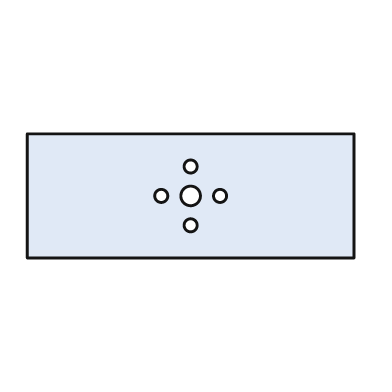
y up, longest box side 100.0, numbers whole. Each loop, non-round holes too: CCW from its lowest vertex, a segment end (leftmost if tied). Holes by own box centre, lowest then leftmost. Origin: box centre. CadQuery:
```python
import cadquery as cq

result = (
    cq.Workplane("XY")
    .moveTo(-50.0, -19.0)
    .lineTo(50.0, -19.0)
    .lineTo(50.0, 19.0)
    .lineTo(-50.0, 19.0)
    .close()
    .moveTo(0.0, -9.0)
    .circle(2.0)
    .moveTo(-9.0, 0.0)
    .circle(2.0)
    .moveTo(0.0, 0.0)
    .circle(3.0)
    .moveTo(9.0, 0.0)
    .circle(2.0)
    .moveTo(0.0, 9.0)
    .circle(2.0)
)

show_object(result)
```